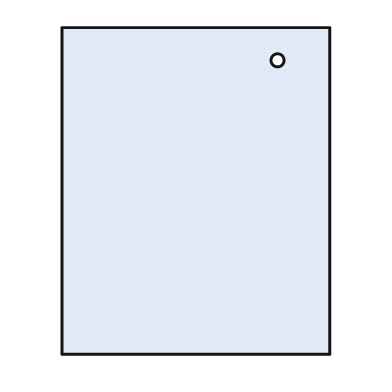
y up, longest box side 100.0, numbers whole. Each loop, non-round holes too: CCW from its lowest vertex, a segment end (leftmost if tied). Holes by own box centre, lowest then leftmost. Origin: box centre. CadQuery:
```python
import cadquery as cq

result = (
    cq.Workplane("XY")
    .moveTo(-41.0, -50.0)
    .lineTo(41.0, -50.0)
    .lineTo(41.0, 50.0)
    .lineTo(-41.0, 50.0)
    .close()
    .moveTo(25.0, 40.0)
    .circle(2.0)
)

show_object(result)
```